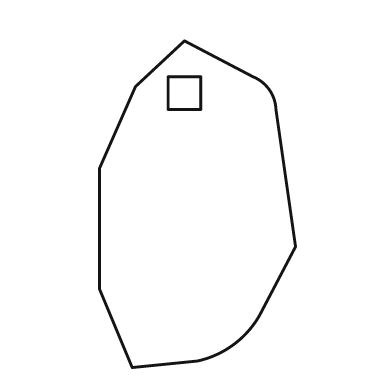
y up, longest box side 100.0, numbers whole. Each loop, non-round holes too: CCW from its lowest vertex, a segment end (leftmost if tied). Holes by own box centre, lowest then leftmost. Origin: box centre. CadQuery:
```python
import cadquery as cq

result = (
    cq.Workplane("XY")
    .moveTo(-20.0, -50.0)
    .lineTo(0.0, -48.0)
    .threePointArc((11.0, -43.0), (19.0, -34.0))
    .lineTo(30.0, -13.0)
    .lineTo(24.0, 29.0)
    .threePointArc((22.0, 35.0), (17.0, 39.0))
    .lineTo(-4.0, 50.0)
    .lineTo(-19.0, 36.0)
    .lineTo(-30.0, 11.0)
    .lineTo(-30.0, -26.0)
    .close()
    .moveTo(-9.0, 29.0)
    .lineTo(1.0, 29.0)
    .lineTo(1.0, 39.0)
    .lineTo(-9.0, 39.0)
    .close()
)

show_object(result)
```